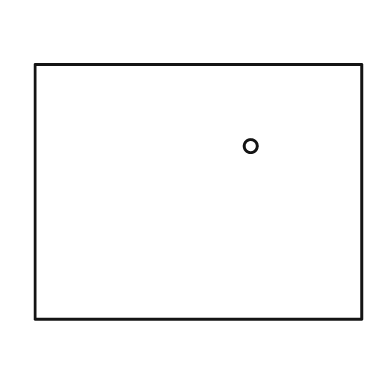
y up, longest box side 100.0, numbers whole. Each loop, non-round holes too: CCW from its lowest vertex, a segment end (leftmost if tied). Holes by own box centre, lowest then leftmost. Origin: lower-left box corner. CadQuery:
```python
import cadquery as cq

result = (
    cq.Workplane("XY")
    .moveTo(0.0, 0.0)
    .lineTo(100.0, 0.0)
    .lineTo(100.0, 78.0)
    .lineTo(0.0, 78.0)
    .close()
    .moveTo(66.0, 53.0)
    .circle(2.0)
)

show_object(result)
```